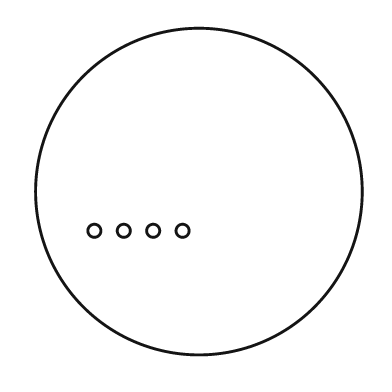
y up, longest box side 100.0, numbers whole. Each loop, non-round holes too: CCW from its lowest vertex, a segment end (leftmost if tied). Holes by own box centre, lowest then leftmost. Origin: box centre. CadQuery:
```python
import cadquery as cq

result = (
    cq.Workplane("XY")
    .moveTo(0.0, 0.0)
    .circle(50.0)
    .moveTo(-32.0, -12.0)
    .circle(2.0)
    .moveTo(-23.0, -12.0)
    .circle(2.0)
    .moveTo(-14.0, -12.0)
    .circle(2.0)
    .moveTo(-5.0, -12.0)
    .circle(2.0)
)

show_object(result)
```